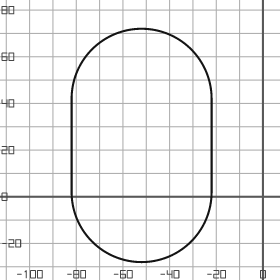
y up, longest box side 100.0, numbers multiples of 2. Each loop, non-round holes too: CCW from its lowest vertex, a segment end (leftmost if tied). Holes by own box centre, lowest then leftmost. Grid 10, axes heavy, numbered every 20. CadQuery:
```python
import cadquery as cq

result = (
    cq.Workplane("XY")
    .moveTo(-82.0, 2.0)
    .threePointArc((-52.0, -28.0), (-22.0, 2.0))
    .lineTo(-22.0, 42.0)
    .threePointArc((-52.0, 72.0), (-82.0, 42.0))
    .close()
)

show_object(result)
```